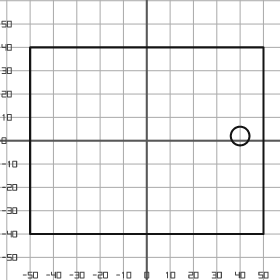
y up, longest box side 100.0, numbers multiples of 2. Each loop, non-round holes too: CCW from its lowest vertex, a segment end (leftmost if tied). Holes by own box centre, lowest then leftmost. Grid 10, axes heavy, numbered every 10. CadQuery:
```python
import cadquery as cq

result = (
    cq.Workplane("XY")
    .moveTo(-50.0, -40.0)
    .lineTo(50.0, -40.0)
    .lineTo(50.0, 40.0)
    .lineTo(-50.0, 40.0)
    .close()
    .moveTo(40.0, 2.0)
    .circle(4.0)
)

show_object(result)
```